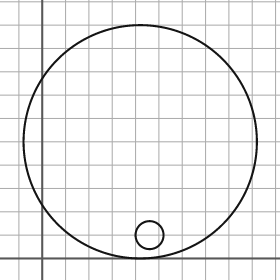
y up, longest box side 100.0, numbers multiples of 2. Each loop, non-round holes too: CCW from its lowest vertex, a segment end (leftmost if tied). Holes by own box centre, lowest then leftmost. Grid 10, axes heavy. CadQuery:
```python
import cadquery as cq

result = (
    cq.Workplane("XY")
    .moveTo(42.0, 50.0)
    .circle(50.0)
    .moveTo(46.0, 10.0)
    .circle(6.0)
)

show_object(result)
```